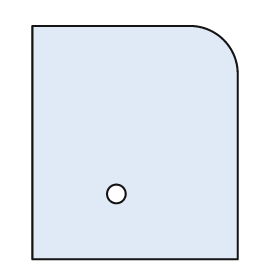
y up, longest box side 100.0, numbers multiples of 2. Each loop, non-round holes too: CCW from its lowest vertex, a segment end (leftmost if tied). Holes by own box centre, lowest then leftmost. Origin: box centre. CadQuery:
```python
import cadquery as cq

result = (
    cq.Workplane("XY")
    .moveTo(-44.0, -50.0)
    .lineTo(44.0, -50.0)
    .lineTo(44.0, 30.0)
    .threePointArc((38.0, 44.0), (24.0, 50.0))
    .lineTo(-44.0, 50.0)
    .close()
    .moveTo(-8.0, -22.0)
    .circle(4.0)
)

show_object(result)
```